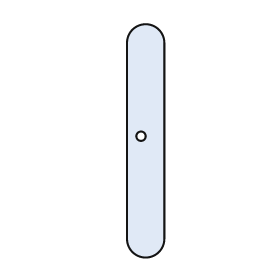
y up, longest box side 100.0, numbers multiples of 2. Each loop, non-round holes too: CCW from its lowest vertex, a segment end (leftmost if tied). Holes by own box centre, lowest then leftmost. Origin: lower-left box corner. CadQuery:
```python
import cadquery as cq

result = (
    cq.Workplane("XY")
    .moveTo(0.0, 8.0)
    .threePointArc((8.0, 0.0), (16.0, 8.0))
    .lineTo(16.0, 92.0)
    .threePointArc((8.0, 100.0), (0.0, 92.0))
    .close()
    .moveTo(6.0, 52.0)
    .circle(2.0)
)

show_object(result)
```